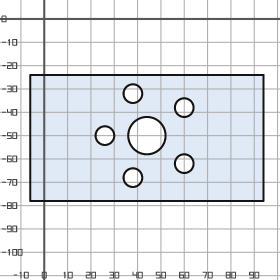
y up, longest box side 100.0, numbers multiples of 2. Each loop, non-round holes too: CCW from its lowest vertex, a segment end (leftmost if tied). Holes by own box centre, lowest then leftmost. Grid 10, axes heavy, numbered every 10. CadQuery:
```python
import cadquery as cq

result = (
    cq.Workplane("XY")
    .moveTo(-6.0, -78.0)
    .lineTo(94.0, -78.0)
    .lineTo(94.0, -24.0)
    .lineTo(-6.0, -24.0)
    .close()
    .moveTo(38.0, -68.0)
    .circle(4.0)
    .moveTo(60.0, -62.0)
    .circle(4.0)
    .moveTo(26.0, -50.0)
    .circle(4.0)
    .moveTo(44.0, -50.0)
    .circle(8.0)
    .moveTo(60.0, -38.0)
    .circle(4.0)
    .moveTo(38.0, -32.0)
    .circle(4.0)
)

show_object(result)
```